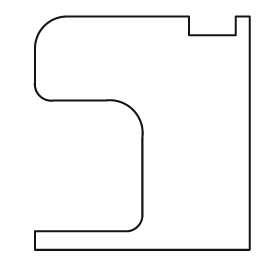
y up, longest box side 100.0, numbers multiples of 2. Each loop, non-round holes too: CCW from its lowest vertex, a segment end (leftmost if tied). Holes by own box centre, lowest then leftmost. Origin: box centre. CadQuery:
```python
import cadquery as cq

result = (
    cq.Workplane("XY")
    .moveTo(-46.0, -50.0)
    .lineTo(46.0, -50.0)
    .lineTo(46.0, 50.0)
    .lineTo(40.0, 50.0)
    .lineTo(40.0, 42.0)
    .lineTo(20.0, 42.0)
    .lineTo(20.0, 50.0)
    .lineTo(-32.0, 50.0)
    .threePointArc((-42.0, 46.0), (-46.0, 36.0))
    .lineTo(-46.0, 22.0)
    .threePointArc((-44.0, 16.0), (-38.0, 14.0))
    .lineTo(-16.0, 14.0)
    .threePointArc((-4.0, 10.0), (0.0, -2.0))
    .lineTo(0.0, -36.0)
    .threePointArc((-2.0, -40.0), (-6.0, -42.0))
    .lineTo(-46.0, -42.0)
    .close()
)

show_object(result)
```